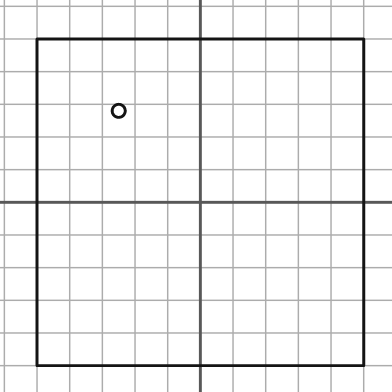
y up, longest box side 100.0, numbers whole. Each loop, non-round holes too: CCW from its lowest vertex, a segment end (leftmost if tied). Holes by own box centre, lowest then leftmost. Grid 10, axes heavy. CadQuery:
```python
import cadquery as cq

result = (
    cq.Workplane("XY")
    .moveTo(-50.0, -50.0)
    .lineTo(50.0, -50.0)
    .lineTo(50.0, 50.0)
    .lineTo(-50.0, 50.0)
    .close()
    .moveTo(-25.0, 28.0)
    .circle(2.0)
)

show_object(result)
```